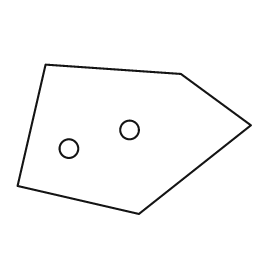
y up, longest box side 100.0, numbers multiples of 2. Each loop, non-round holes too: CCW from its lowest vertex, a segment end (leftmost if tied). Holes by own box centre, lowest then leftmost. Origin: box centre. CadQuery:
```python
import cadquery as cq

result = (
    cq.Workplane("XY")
    .moveTo(2.0, -32.0)
    .lineTo(50.0, 6.0)
    .lineTo(20.0, 28.0)
    .lineTo(-38.0, 32.0)
    .lineTo(-50.0, -20.0)
    .close()
    .moveTo(-28.0, -4.0)
    .circle(4.0)
    .moveTo(-2.0, 4.0)
    .circle(4.0)
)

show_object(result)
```